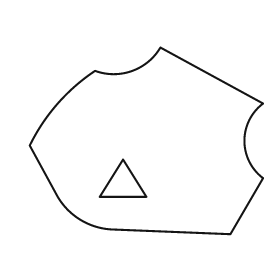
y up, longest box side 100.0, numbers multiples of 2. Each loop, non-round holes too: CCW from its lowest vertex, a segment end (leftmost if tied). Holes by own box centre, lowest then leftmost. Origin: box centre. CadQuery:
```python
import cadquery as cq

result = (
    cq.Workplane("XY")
    .moveTo(36.0, -40.0)
    .lineTo(50.0, -16.0)
    .threePointArc((42.0, 0.0), (50.0, 16.0))
    .lineTo(6.0, 40.0)
    .threePointArc((-6.0, 30.0), (-22.0, 30.0))
    .threePointArc((-38.0, 16.0), (-50.0, -2.0))
    .lineTo(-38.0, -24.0)
    .threePointArc((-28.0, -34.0), (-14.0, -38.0))
    .close()
    .moveTo(-20.0, -24.0)
    .lineTo(0.0, -24.0)
    .lineTo(-10.0, -8.0)
    .close()
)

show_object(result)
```